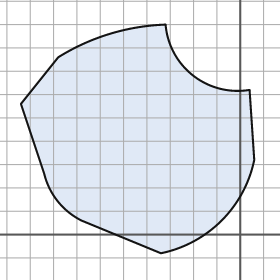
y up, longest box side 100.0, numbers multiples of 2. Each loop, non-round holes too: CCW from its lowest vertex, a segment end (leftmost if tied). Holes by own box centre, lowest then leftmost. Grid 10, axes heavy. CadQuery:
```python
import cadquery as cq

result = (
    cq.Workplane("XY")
    .moveTo(-34.0, -8.0)
    .threePointArc((-8.0, 6.0), (6.0, 32.0))
    .lineTo(4.0, 62.0)
    .threePointArc((-20.0, 68.0), (-32.0, 90.0))
    .threePointArc((-56.0, 86.0), (-78.0, 76.0))
    .lineTo(-94.0, 56.0)
    .lineTo(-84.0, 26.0)
    .threePointArc((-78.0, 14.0), (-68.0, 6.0))
    .close()
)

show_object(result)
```